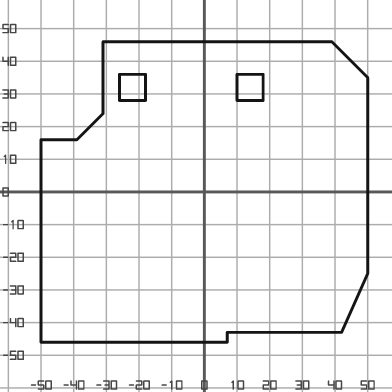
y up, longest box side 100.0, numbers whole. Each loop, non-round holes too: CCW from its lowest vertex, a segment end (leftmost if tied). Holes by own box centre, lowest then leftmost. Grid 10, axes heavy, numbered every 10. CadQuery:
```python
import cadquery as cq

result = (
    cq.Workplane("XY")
    .moveTo(-50.0, -46.0)
    .lineTo(7.0, -46.0)
    .lineTo(7.0, -43.0)
    .lineTo(42.0, -43.0)
    .lineTo(50.0, -25.0)
    .lineTo(50.0, 35.0)
    .lineTo(39.0, 46.0)
    .lineTo(-31.0, 46.0)
    .lineTo(-31.0, 24.0)
    .lineTo(-39.0, 16.0)
    .lineTo(-50.0, 16.0)
    .close()
    .moveTo(-26.0, 28.0)
    .lineTo(-18.0, 28.0)
    .lineTo(-18.0, 36.0)
    .lineTo(-26.0, 36.0)
    .close()
    .moveTo(10.0, 28.0)
    .lineTo(18.0, 28.0)
    .lineTo(18.0, 36.0)
    .lineTo(10.0, 36.0)
    .close()
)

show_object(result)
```